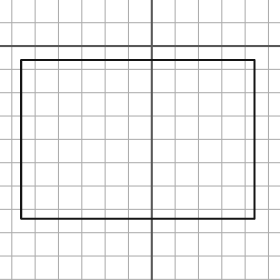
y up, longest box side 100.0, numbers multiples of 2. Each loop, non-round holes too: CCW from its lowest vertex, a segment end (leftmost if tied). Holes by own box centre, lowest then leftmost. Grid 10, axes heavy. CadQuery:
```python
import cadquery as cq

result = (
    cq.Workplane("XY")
    .moveTo(-56.0, -74.0)
    .lineTo(44.0, -74.0)
    .lineTo(44.0, -6.0)
    .lineTo(-56.0, -6.0)
    .close()
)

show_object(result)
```